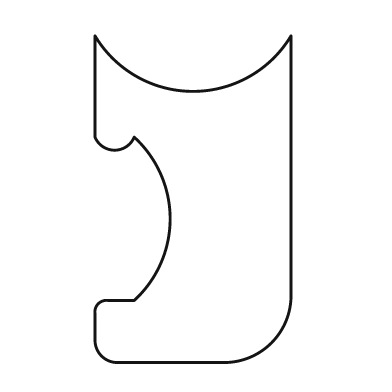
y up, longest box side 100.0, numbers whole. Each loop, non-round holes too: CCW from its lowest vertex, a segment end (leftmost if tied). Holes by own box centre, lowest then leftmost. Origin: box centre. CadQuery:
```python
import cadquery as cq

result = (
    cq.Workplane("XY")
    .moveTo(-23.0, -50.0)
    .lineTo(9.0, -50.0)
    .threePointArc((24.0, -44.0), (30.0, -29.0))
    .lineTo(30.0, 50.0)
    .threePointArc((0.0, 33.0), (-30.0, 50.0))
    .lineTo(-30.0, 19.0)
    .threePointArc((-24.0, 15.0), (-18.0, 19.0))
    .threePointArc((-7.0, -6.0), (-18.0, -31.0))
    .lineTo(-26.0, -31.0)
    .threePointArc((-29.0, -32.0), (-30.0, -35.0))
    .lineTo(-30.0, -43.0)
    .threePointArc((-28.0, -48.0), (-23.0, -50.0))
    .close()
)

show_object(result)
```